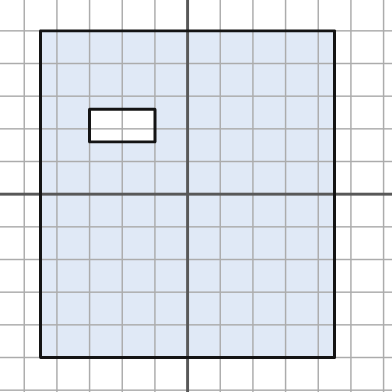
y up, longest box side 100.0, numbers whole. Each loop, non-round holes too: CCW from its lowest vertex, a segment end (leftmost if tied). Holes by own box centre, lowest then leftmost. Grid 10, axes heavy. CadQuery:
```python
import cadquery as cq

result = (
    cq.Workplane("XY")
    .moveTo(-45.0, -50.0)
    .lineTo(45.0, -50.0)
    .lineTo(45.0, 50.0)
    .lineTo(-45.0, 50.0)
    .close()
    .moveTo(-30.0, 16.0)
    .lineTo(-10.0, 16.0)
    .lineTo(-10.0, 26.0)
    .lineTo(-30.0, 26.0)
    .close()
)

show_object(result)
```